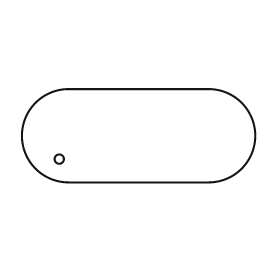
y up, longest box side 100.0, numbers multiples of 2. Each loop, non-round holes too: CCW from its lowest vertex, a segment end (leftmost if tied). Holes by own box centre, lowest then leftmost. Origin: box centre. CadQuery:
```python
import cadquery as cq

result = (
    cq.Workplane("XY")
    .moveTo(-30.0, -20.0)
    .lineTo(30.0, -20.0)
    .threePointArc((50.0, 0.0), (30.0, 20.0))
    .lineTo(-30.0, 20.0)
    .threePointArc((-50.0, 0.0), (-30.0, -20.0))
    .close()
    .moveTo(-34.0, -10.0)
    .circle(2.0)
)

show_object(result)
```